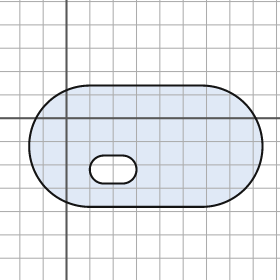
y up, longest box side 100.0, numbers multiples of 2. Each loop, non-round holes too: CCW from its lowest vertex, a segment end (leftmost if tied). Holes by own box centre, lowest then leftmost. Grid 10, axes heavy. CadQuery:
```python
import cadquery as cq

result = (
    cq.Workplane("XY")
    .moveTo(10.0, -38.0)
    .lineTo(58.0, -38.0)
    .threePointArc((84.0, -12.0), (58.0, 14.0))
    .lineTo(10.0, 14.0)
    .threePointArc((-16.0, -12.0), (10.0, -38.0))
    .close()
    .moveTo(16.0, -28.0)
    .lineTo(24.0, -28.0)
    .threePointArc((30.0, -22.0), (24.0, -16.0))
    .lineTo(16.0, -16.0)
    .threePointArc((10.0, -22.0), (16.0, -28.0))
    .close()
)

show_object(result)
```